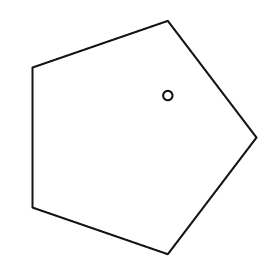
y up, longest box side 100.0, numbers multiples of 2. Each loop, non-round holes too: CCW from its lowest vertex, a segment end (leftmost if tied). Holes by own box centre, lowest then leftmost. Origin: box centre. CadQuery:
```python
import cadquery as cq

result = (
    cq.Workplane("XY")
    .moveTo(10.0, -50.0)
    .lineTo(48.0, 0.0)
    .lineTo(10.0, 50.0)
    .lineTo(-48.0, 30.0)
    .lineTo(-48.0, -30.0)
    .close()
    .moveTo(10.0, 18.0)
    .circle(2.0)
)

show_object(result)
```